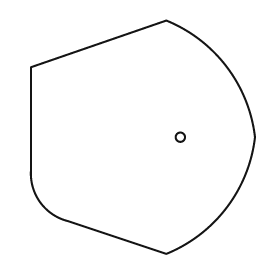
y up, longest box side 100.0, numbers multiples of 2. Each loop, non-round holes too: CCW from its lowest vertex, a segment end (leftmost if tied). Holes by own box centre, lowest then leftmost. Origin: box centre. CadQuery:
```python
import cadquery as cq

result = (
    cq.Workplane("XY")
    .moveTo(10.0, -50.0)
    .threePointArc((36.0, -30.0), (48.0, 0.0))
    .threePointArc((36.0, 30.0), (10.0, 50.0))
    .lineTo(-48.0, 30.0)
    .lineTo(-48.0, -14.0)
    .threePointArc((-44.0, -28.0), (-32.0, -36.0))
    .close()
    .moveTo(16.0, 0.0)
    .circle(2.0)
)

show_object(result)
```